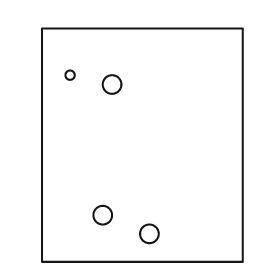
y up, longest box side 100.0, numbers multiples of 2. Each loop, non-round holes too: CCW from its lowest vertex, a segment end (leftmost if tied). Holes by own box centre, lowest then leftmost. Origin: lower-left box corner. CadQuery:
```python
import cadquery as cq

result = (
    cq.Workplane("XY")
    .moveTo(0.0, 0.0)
    .lineTo(86.0, 0.0)
    .lineTo(86.0, 100.0)
    .lineTo(0.0, 100.0)
    .close()
    .moveTo(46.0, 12.0)
    .circle(4.0)
    .moveTo(26.0, 20.0)
    .circle(4.0)
    .moveTo(30.0, 76.0)
    .circle(4.0)
    .moveTo(12.0, 80.0)
    .circle(2.0)
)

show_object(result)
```